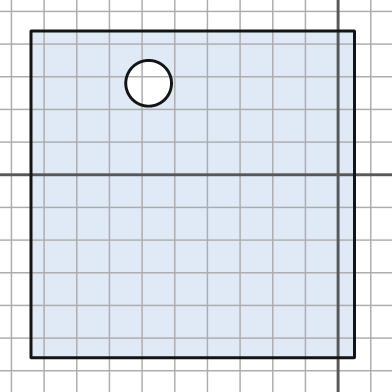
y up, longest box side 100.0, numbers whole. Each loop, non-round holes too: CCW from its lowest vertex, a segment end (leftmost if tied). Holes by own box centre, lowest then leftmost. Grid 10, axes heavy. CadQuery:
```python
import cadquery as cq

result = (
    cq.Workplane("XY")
    .moveTo(-94.0, -56.0)
    .lineTo(5.0, -56.0)
    .lineTo(5.0, 44.0)
    .lineTo(-94.0, 44.0)
    .close()
    .moveTo(-58.0, 28.0)
    .circle(7.0)
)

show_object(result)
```